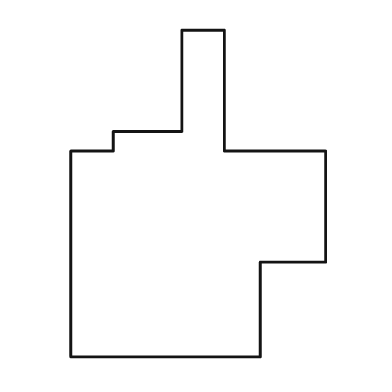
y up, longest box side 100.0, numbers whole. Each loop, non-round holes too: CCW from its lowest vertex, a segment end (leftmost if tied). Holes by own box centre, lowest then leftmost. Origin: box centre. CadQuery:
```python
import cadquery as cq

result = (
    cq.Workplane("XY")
    .moveTo(-39.0, -50.0)
    .lineTo(19.0, -50.0)
    .lineTo(19.0, -21.0)
    .lineTo(39.0, -21.0)
    .lineTo(39.0, 13.0)
    .lineTo(8.0, 13.0)
    .lineTo(8.0, 50.0)
    .lineTo(-5.0, 50.0)
    .lineTo(-5.0, 19.0)
    .lineTo(-26.0, 19.0)
    .lineTo(-26.0, 13.0)
    .lineTo(-39.0, 13.0)
    .close()
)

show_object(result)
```